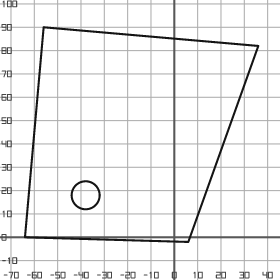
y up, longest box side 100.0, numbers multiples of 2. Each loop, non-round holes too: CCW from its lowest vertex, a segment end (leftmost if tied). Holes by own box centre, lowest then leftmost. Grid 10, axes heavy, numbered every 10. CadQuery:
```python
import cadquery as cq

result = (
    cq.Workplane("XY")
    .moveTo(6.0, -2.0)
    .lineTo(36.0, 82.0)
    .lineTo(-56.0, 90.0)
    .lineTo(-64.0, 0.0)
    .close()
    .moveTo(-38.0, 18.0)
    .circle(6.0)
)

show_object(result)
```